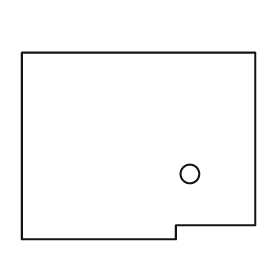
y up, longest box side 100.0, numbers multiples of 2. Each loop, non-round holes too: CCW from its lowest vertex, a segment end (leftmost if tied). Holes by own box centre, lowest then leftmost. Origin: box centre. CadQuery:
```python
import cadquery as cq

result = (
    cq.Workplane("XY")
    .moveTo(-50.0, -40.0)
    .lineTo(16.0, -40.0)
    .lineTo(16.0, -34.0)
    .lineTo(50.0, -34.0)
    .lineTo(50.0, 40.0)
    .lineTo(-50.0, 40.0)
    .close()
    .moveTo(22.0, -12.0)
    .circle(4.0)
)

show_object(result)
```